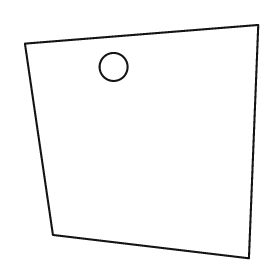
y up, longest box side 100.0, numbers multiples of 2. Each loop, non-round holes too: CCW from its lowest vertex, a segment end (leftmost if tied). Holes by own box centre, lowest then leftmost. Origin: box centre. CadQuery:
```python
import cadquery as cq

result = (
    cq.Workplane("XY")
    .moveTo(46.0, -50.0)
    .lineTo(50.0, 50.0)
    .lineTo(-50.0, 42.0)
    .lineTo(-38.0, -40.0)
    .close()
    .moveTo(-12.0, 32.0)
    .circle(6.0)
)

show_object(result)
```